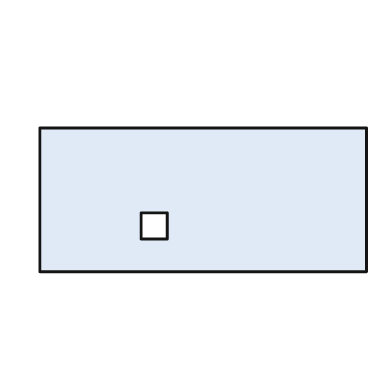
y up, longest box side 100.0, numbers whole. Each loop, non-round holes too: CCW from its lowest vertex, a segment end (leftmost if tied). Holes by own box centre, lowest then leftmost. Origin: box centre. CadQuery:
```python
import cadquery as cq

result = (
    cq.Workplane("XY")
    .moveTo(-50.0, -22.0)
    .lineTo(50.0, -22.0)
    .lineTo(50.0, 22.0)
    .lineTo(-50.0, 22.0)
    .close()
    .moveTo(-19.0, -12.0)
    .lineTo(-11.0, -12.0)
    .lineTo(-11.0, -4.0)
    .lineTo(-19.0, -4.0)
    .close()
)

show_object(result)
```